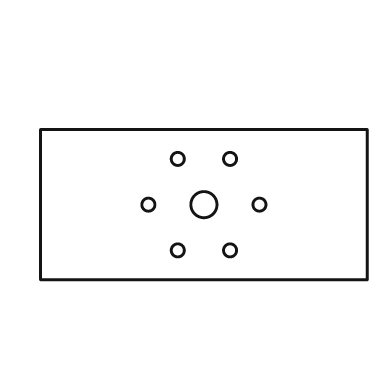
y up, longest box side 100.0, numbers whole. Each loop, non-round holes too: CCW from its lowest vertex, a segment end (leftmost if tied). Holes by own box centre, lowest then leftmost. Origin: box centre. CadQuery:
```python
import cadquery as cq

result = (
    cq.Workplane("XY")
    .moveTo(-50.0, -23.0)
    .lineTo(50.0, -23.0)
    .lineTo(50.0, 23.0)
    .lineTo(-50.0, 23.0)
    .close()
    .moveTo(-8.0, -14.0)
    .circle(2.0)
    .moveTo(8.0, -14.0)
    .circle(2.0)
    .moveTo(-17.0, 0.0)
    .circle(2.0)
    .moveTo(0.0, 0.0)
    .circle(4.0)
    .moveTo(17.0, 0.0)
    .circle(2.0)
    .moveTo(-8.0, 14.0)
    .circle(2.0)
    .moveTo(8.0, 14.0)
    .circle(2.0)
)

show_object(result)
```